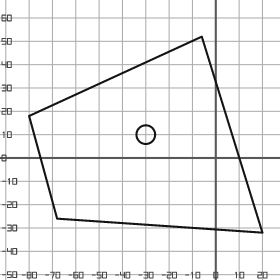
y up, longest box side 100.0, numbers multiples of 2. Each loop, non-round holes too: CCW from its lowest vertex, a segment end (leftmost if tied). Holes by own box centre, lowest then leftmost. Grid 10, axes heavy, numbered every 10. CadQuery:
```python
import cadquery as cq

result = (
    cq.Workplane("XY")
    .moveTo(20.0, -32.0)
    .lineTo(-6.0, 52.0)
    .lineTo(-80.0, 18.0)
    .lineTo(-68.0, -26.0)
    .close()
    .moveTo(-30.0, 10.0)
    .circle(4.0)
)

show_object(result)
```